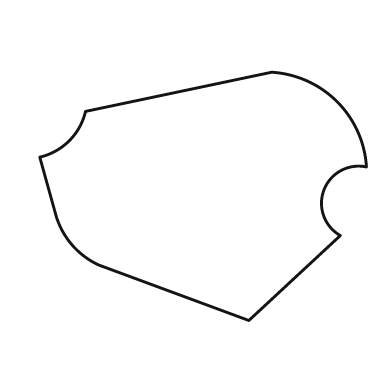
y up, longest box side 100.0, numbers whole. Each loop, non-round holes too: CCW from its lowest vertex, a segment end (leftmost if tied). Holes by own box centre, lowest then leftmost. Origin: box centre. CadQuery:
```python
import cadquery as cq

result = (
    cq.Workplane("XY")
    .moveTo(14.0, -38.0)
    .lineTo(42.0, -12.0)
    .threePointArc((37.0, 2.0), (50.0, 9.0))
    .threePointArc((41.0, 29.0), (21.0, 38.0))
    .lineTo(-36.0, 26.0)
    .threePointArc((-41.0, 17.0), (-50.0, 12.0))
    .lineTo(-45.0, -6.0)
    .threePointArc((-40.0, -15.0), (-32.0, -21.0))
    .close()
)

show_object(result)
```